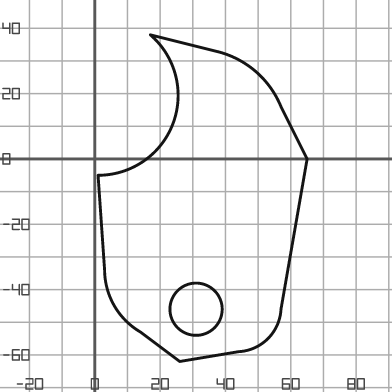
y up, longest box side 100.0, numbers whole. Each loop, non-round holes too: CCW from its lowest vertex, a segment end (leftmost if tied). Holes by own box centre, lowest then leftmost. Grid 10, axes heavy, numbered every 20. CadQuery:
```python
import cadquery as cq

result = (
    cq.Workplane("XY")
    .moveTo(26.0, -62.0)
    .lineTo(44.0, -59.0)
    .threePointArc((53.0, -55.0), (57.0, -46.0))
    .lineTo(65.0, 0.0)
    .lineTo(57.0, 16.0)
    .threePointArc((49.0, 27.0), (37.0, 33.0))
    .lineTo(17.0, 38.0)
    .threePointArc((24.0, 11.0), (1.0, -5.0))
    .lineTo(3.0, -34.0)
    .threePointArc((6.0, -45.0), (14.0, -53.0))
    .close()
    .moveTo(31.0, -46.0)
    .circle(8.0)
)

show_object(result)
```